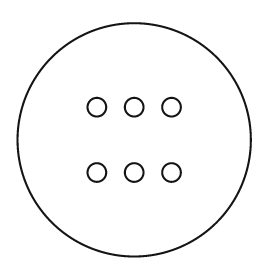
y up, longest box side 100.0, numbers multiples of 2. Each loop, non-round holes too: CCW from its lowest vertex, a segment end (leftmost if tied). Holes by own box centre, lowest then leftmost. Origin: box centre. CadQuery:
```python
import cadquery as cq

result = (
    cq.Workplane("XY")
    .moveTo(0.0, 0.0)
    .circle(50.0)
    .moveTo(-16.0, -14.0)
    .circle(4.0)
    .moveTo(0.0, -14.0)
    .circle(4.0)
    .moveTo(16.0, -14.0)
    .circle(4.0)
    .moveTo(-16.0, 14.0)
    .circle(4.0)
    .moveTo(0.0, 14.0)
    .circle(4.0)
    .moveTo(16.0, 14.0)
    .circle(4.0)
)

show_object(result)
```